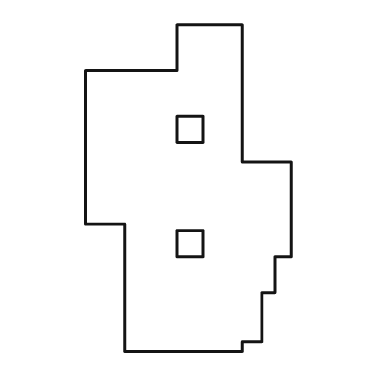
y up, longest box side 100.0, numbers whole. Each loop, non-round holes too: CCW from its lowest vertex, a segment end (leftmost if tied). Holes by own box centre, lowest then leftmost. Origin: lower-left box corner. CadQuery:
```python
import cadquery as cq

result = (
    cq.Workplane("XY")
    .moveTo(12.0, 0.0)
    .lineTo(48.0, 0.0)
    .lineTo(48.0, 3.0)
    .lineTo(54.0, 3.0)
    .lineTo(54.0, 18.0)
    .lineTo(58.0, 18.0)
    .lineTo(58.0, 29.0)
    .lineTo(63.0, 29.0)
    .lineTo(63.0, 58.0)
    .lineTo(48.0, 58.0)
    .lineTo(48.0, 100.0)
    .lineTo(28.0, 100.0)
    .lineTo(28.0, 86.0)
    .lineTo(0.0, 86.0)
    .lineTo(0.0, 39.0)
    .lineTo(12.0, 39.0)
    .close()
    .moveTo(28.0, 29.0)
    .lineTo(36.0, 29.0)
    .lineTo(36.0, 37.0)
    .lineTo(28.0, 37.0)
    .close()
    .moveTo(28.0, 64.0)
    .lineTo(36.0, 64.0)
    .lineTo(36.0, 72.0)
    .lineTo(28.0, 72.0)
    .close()
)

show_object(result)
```